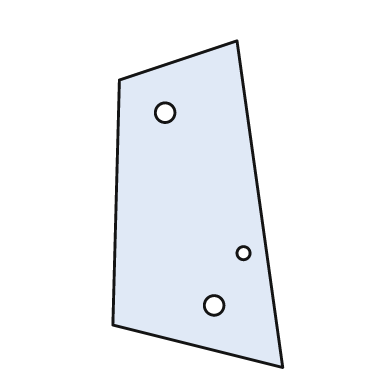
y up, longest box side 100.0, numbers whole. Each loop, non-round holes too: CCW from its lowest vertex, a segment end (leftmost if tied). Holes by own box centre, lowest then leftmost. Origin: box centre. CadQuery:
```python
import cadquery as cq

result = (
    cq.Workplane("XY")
    .moveTo(26.0, -50.0)
    .lineTo(12.0, 50.0)
    .lineTo(-24.0, 38.0)
    .lineTo(-26.0, -37.0)
    .close()
    .moveTo(5.0, -31.0)
    .circle(3.0)
    .moveTo(14.0, -15.0)
    .circle(2.0)
    .moveTo(-10.0, 28.0)
    .circle(3.0)
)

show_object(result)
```